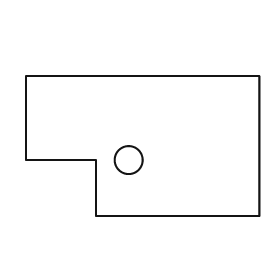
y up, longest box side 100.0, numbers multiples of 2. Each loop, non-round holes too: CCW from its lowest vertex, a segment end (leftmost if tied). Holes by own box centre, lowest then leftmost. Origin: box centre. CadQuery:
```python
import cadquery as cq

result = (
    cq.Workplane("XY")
    .moveTo(-20.0, -30.0)
    .lineTo(50.0, -30.0)
    .lineTo(50.0, 30.0)
    .lineTo(-50.0, 30.0)
    .lineTo(-50.0, -6.0)
    .lineTo(-20.0, -6.0)
    .close()
    .moveTo(-6.0, -6.0)
    .circle(6.0)
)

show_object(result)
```